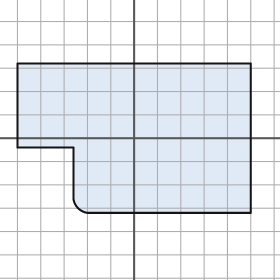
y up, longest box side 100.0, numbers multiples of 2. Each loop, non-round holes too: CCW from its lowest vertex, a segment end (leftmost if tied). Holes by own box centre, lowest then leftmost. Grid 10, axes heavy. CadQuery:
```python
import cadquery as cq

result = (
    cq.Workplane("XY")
    .moveTo(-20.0, -32.0)
    .lineTo(50.0, -32.0)
    .lineTo(50.0, 32.0)
    .lineTo(-50.0, 32.0)
    .lineTo(-50.0, -4.0)
    .lineTo(-26.0, -4.0)
    .lineTo(-26.0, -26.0)
    .threePointArc((-24.0, -30.0), (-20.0, -32.0))
    .close()
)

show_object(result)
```